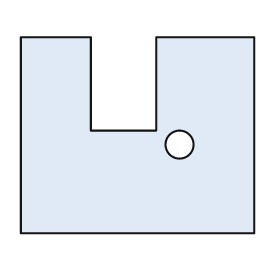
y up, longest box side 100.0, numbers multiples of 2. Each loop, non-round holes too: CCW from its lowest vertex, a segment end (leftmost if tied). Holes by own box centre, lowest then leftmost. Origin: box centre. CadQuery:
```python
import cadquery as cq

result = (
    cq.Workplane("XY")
    .moveTo(-50.0, -42.0)
    .lineTo(50.0, -42.0)
    .lineTo(50.0, 42.0)
    .lineTo(8.0, 42.0)
    .lineTo(8.0, 2.0)
    .lineTo(-20.0, 2.0)
    .lineTo(-20.0, 42.0)
    .lineTo(-50.0, 42.0)
    .close()
    .moveTo(18.0, -4.0)
    .circle(6.0)
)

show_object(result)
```